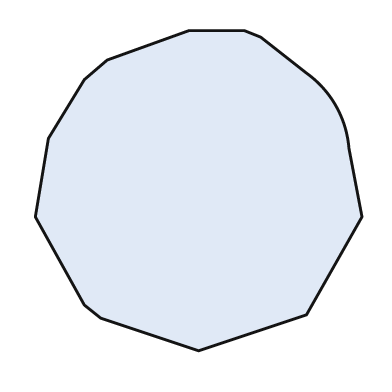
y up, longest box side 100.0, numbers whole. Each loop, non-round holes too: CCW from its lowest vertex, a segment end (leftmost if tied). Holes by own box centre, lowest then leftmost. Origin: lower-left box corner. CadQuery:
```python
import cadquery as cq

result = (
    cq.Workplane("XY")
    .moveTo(50.0, 0.0)
    .lineTo(83.0, 11.0)
    .lineTo(100.0, 41.0)
    .lineTo(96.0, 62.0)
    .threePointArc((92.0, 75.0), (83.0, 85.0))
    .lineTo(69.0, 96.0)
    .lineTo(64.0, 98.0)
    .lineTo(47.0, 98.0)
    .lineTo(22.0, 89.0)
    .lineTo(15.0, 83.0)
    .lineTo(4.0, 65.0)
    .lineTo(0.0, 41.0)
    .lineTo(15.0, 14.0)
    .lineTo(20.0, 10.0)
    .close()
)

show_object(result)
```